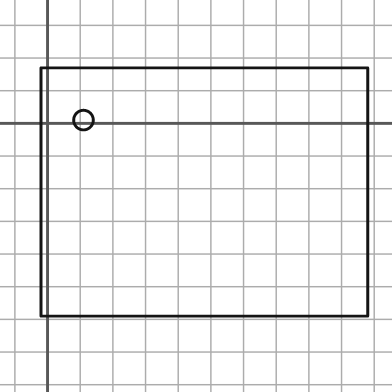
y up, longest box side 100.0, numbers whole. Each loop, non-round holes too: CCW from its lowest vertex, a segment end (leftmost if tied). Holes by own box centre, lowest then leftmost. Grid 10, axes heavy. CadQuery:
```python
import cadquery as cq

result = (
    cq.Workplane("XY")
    .moveTo(-2.0, -59.0)
    .lineTo(98.0, -59.0)
    .lineTo(98.0, 17.0)
    .lineTo(-2.0, 17.0)
    .close()
    .moveTo(11.0, 1.0)
    .circle(3.0)
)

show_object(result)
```